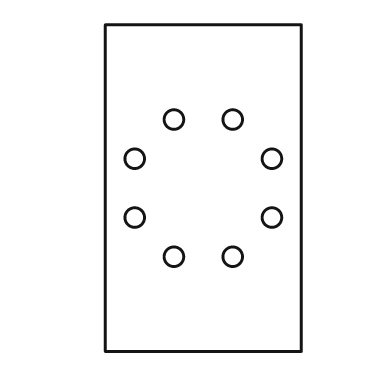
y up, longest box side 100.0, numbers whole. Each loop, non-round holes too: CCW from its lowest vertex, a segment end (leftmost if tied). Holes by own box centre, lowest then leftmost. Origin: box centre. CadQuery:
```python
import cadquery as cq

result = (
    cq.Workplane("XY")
    .moveTo(-30.0, -50.0)
    .lineTo(30.0, -50.0)
    .lineTo(30.0, 50.0)
    .lineTo(-30.0, 50.0)
    .close()
    .moveTo(-9.0, -21.0)
    .circle(3.0)
    .moveTo(9.0, -21.0)
    .circle(3.0)
    .moveTo(-21.0, -9.0)
    .circle(3.0)
    .moveTo(21.0, -9.0)
    .circle(3.0)
    .moveTo(-21.0, 9.0)
    .circle(3.0)
    .moveTo(21.0, 9.0)
    .circle(3.0)
    .moveTo(-9.0, 21.0)
    .circle(3.0)
    .moveTo(9.0, 21.0)
    .circle(3.0)
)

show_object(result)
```